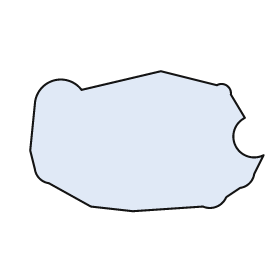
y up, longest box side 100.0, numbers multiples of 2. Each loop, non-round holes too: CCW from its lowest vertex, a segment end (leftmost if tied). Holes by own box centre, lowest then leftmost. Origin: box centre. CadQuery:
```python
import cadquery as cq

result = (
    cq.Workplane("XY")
    .moveTo(-6.0, -30.0)
    .lineTo(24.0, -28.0)
    .threePointArc((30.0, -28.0), (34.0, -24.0))
    .lineTo(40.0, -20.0)
    .threePointArc((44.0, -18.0), (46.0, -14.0))
    .lineTo(50.0, -6.0)
    .threePointArc((38.0, -2.0), (42.0, 10.0))
    .lineTo(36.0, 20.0)
    .threePointArc((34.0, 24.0), (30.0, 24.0))
    .lineTo(6.0, 30.0)
    .lineTo(-28.0, 22.0)
    .threePointArc((-40.0, 26.0), (-48.0, 16.0))
    .lineTo(-50.0, -4.0)
    .lineTo(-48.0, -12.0)
    .threePointArc((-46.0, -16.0), (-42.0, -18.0))
    .lineTo(-24.0, -28.0)
    .close()
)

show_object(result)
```